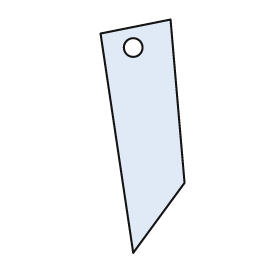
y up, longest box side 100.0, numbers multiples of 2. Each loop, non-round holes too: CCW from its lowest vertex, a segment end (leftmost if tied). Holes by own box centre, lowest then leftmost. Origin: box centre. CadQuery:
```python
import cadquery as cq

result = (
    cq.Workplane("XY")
    .moveTo(-4.0, -50.0)
    .lineTo(18.0, -20.0)
    .lineTo(12.0, 50.0)
    .lineTo(-18.0, 44.0)
    .close()
    .moveTo(-4.0, 38.0)
    .circle(4.0)
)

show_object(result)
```